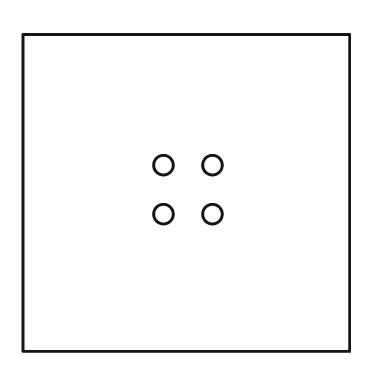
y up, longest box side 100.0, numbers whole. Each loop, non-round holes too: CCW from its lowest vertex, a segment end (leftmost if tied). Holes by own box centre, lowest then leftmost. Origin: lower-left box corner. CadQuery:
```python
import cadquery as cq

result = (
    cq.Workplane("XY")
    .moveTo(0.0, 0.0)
    .lineTo(100.0, 0.0)
    .lineTo(100.0, 97.0)
    .lineTo(0.0, 97.0)
    .close()
    .moveTo(43.0, 42.0)
    .circle(3.0)
    .moveTo(58.0, 42.0)
    .circle(3.0)
    .moveTo(43.0, 57.0)
    .circle(3.0)
    .moveTo(58.0, 57.0)
    .circle(3.0)
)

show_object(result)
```